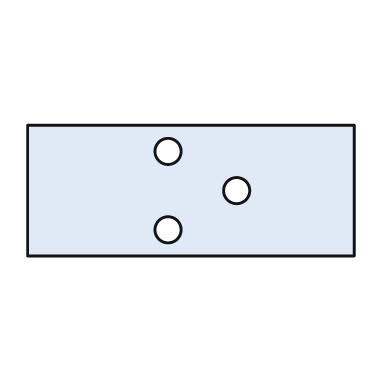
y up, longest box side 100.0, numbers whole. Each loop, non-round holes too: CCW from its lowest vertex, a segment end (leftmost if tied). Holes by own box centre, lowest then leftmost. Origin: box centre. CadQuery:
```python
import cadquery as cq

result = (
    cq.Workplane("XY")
    .moveTo(-50.0, -20.0)
    .lineTo(50.0, -20.0)
    .lineTo(50.0, 20.0)
    .lineTo(-50.0, 20.0)
    .close()
    .moveTo(-7.0, -12.0)
    .circle(4.0)
    .moveTo(14.0, 0.0)
    .circle(4.0)
    .moveTo(-7.0, 12.0)
    .circle(4.0)
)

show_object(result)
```